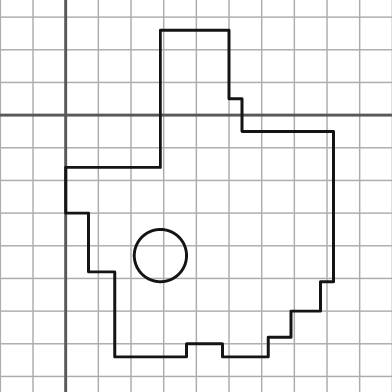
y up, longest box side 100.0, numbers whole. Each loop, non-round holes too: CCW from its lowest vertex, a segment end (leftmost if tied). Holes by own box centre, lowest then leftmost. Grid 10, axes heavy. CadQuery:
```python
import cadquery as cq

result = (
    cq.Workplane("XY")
    .moveTo(15.0, -74.0)
    .lineTo(37.0, -74.0)
    .lineTo(37.0, -70.0)
    .lineTo(48.0, -70.0)
    .lineTo(48.0, -74.0)
    .lineTo(62.0, -74.0)
    .lineTo(62.0, -68.0)
    .lineTo(69.0, -68.0)
    .lineTo(69.0, -60.0)
    .lineTo(78.0, -60.0)
    .lineTo(78.0, -51.0)
    .lineTo(82.0, -51.0)
    .lineTo(82.0, -5.0)
    .lineTo(54.0, -5.0)
    .lineTo(54.0, 5.0)
    .lineTo(50.0, 5.0)
    .lineTo(50.0, 26.0)
    .lineTo(29.0, 26.0)
    .lineTo(29.0, -16.0)
    .lineTo(0.0, -16.0)
    .lineTo(0.0, -30.0)
    .lineTo(7.0, -30.0)
    .lineTo(7.0, -48.0)
    .lineTo(15.0, -48.0)
    .close()
    .moveTo(29.0, -43.0)
    .circle(8.0)
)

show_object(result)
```